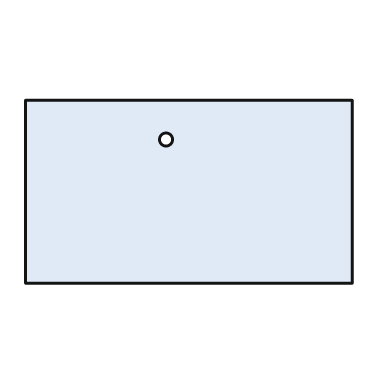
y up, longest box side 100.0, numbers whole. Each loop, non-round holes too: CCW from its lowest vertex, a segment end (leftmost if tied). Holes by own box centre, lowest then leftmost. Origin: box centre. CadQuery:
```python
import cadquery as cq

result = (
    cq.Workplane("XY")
    .moveTo(-50.0, -28.0)
    .lineTo(50.0, -28.0)
    .lineTo(50.0, 28.0)
    .lineTo(-50.0, 28.0)
    .close()
    .moveTo(-7.0, 16.0)
    .circle(2.0)
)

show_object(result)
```